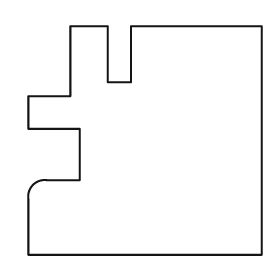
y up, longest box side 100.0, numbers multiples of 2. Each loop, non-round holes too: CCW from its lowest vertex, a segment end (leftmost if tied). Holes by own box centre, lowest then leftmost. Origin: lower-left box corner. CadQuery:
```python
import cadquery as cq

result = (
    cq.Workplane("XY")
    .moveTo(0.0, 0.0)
    .lineTo(100.0, 0.0)
    .lineTo(100.0, 98.0)
    .lineTo(44.0, 98.0)
    .lineTo(44.0, 74.0)
    .lineTo(34.0, 74.0)
    .lineTo(34.0, 98.0)
    .lineTo(18.0, 98.0)
    .lineTo(18.0, 68.0)
    .lineTo(0.0, 68.0)
    .lineTo(0.0, 54.0)
    .lineTo(22.0, 54.0)
    .lineTo(22.0, 32.0)
    .lineTo(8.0, 32.0)
    .threePointArc((2.0, 30.0), (0.0, 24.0))
    .close()
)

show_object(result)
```